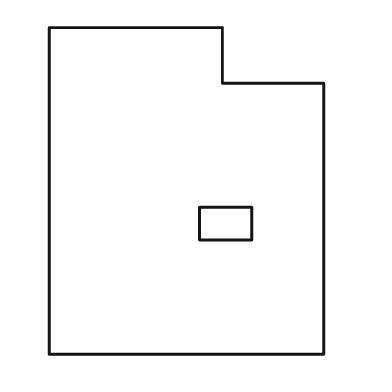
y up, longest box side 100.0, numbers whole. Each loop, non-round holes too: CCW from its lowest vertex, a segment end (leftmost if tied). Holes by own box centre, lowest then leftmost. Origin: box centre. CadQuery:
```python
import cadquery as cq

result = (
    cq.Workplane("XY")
    .moveTo(-42.0, -50.0)
    .lineTo(42.0, -50.0)
    .lineTo(42.0, 33.0)
    .lineTo(11.0, 33.0)
    .lineTo(11.0, 50.0)
    .lineTo(-42.0, 50.0)
    .close()
    .moveTo(4.0, -15.0)
    .lineTo(20.0, -15.0)
    .lineTo(20.0, -5.0)
    .lineTo(4.0, -5.0)
    .close()
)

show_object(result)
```